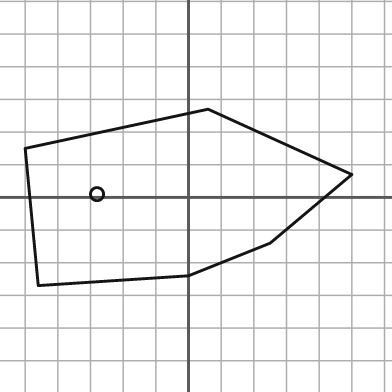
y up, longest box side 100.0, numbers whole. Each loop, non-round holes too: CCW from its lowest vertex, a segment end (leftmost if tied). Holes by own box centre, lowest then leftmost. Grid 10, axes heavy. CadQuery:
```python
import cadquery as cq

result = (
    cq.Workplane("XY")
    .moveTo(-46.0, -27.0)
    .lineTo(0.0, -24.0)
    .lineTo(25.0, -14.0)
    .lineTo(50.0, 7.0)
    .lineTo(6.0, 27.0)
    .lineTo(-50.0, 15.0)
    .close()
    .moveTo(-28.0, 1.0)
    .circle(2.0)
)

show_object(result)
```